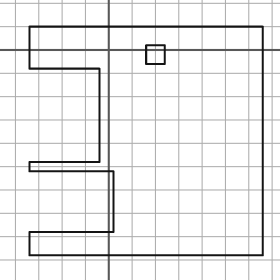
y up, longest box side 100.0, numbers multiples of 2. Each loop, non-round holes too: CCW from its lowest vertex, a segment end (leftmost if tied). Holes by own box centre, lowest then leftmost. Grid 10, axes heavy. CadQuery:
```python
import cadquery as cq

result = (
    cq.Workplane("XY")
    .moveTo(-34.0, -88.0)
    .lineTo(66.0, -88.0)
    .lineTo(66.0, 10.0)
    .lineTo(-34.0, 10.0)
    .lineTo(-34.0, -8.0)
    .lineTo(-4.0, -8.0)
    .lineTo(-4.0, -48.0)
    .lineTo(-34.0, -48.0)
    .lineTo(-34.0, -52.0)
    .lineTo(2.0, -52.0)
    .lineTo(2.0, -78.0)
    .lineTo(-34.0, -78.0)
    .close()
    .moveTo(16.0, -6.0)
    .lineTo(24.0, -6.0)
    .lineTo(24.0, 2.0)
    .lineTo(16.0, 2.0)
    .close()
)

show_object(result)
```